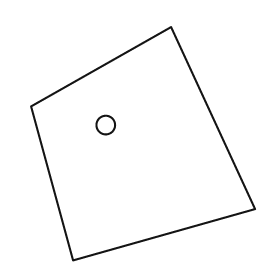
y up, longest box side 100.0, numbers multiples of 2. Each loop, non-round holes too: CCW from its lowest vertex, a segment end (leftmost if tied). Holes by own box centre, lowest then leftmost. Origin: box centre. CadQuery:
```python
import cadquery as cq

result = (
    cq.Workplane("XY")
    .moveTo(-30.0, -50.0)
    .lineTo(48.0, -28.0)
    .lineTo(12.0, 50.0)
    .lineTo(-48.0, 16.0)
    .close()
    .moveTo(-16.0, 8.0)
    .circle(4.0)
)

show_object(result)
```